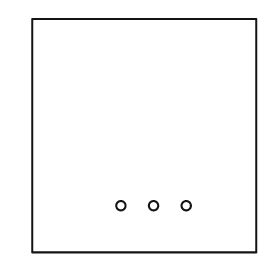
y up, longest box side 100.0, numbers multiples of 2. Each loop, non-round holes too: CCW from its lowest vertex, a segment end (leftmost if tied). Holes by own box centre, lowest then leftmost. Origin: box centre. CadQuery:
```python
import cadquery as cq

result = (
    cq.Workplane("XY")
    .moveTo(-48.0, -50.0)
    .lineTo(48.0, -50.0)
    .lineTo(48.0, 50.0)
    .lineTo(-48.0, 50.0)
    .close()
    .moveTo(-10.0, -30.0)
    .circle(2.0)
    .moveTo(4.0, -30.0)
    .circle(2.0)
    .moveTo(18.0, -30.0)
    .circle(2.0)
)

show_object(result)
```